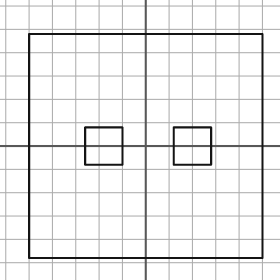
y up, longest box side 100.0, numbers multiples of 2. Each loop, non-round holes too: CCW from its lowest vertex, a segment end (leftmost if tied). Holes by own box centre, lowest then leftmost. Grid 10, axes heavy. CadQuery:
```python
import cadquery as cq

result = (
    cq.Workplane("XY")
    .moveTo(-50.0, -48.0)
    .lineTo(50.0, -48.0)
    .lineTo(50.0, 48.0)
    .lineTo(-50.0, 48.0)
    .close()
    .moveTo(-26.0, -8.0)
    .lineTo(-10.0, -8.0)
    .lineTo(-10.0, 8.0)
    .lineTo(-26.0, 8.0)
    .close()
    .moveTo(12.0, -8.0)
    .lineTo(28.0, -8.0)
    .lineTo(28.0, 8.0)
    .lineTo(12.0, 8.0)
    .close()
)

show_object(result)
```